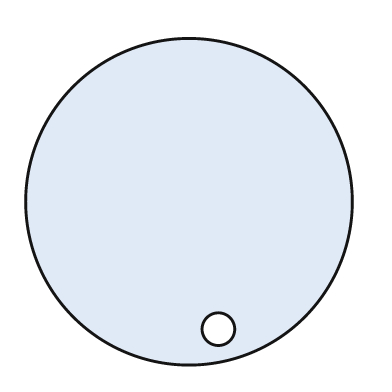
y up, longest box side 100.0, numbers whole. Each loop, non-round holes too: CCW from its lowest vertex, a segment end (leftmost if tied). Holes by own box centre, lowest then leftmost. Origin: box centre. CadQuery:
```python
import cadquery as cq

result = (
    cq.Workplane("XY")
    .moveTo(0.0, 0.0)
    .circle(50.0)
    .moveTo(9.0, -39.0)
    .circle(5.0)
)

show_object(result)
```